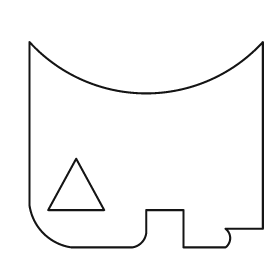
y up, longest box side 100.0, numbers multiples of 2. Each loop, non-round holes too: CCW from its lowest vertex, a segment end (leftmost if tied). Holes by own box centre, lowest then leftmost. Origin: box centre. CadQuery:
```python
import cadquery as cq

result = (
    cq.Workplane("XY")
    .moveTo(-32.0, -44.0)
    .lineTo(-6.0, -44.0)
    .threePointArc((-2.0, -42.0), (0.0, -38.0))
    .lineTo(0.0, -28.0)
    .lineTo(16.0, -28.0)
    .lineTo(16.0, -44.0)
    .lineTo(34.0, -44.0)
    .threePointArc((36.0, -40.0), (34.0, -36.0))
    .lineTo(50.0, -36.0)
    .lineTo(50.0, 44.0)
    .threePointArc((0.0, 22.0), (-50.0, 44.0))
    .lineTo(-50.0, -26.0)
    .threePointArc((-44.0, -38.0), (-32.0, -44.0))
    .close()
    .moveTo(-42.0, -28.0)
    .lineTo(-18.0, -28.0)
    .lineTo(-30.0, -6.0)
    .close()
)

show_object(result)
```